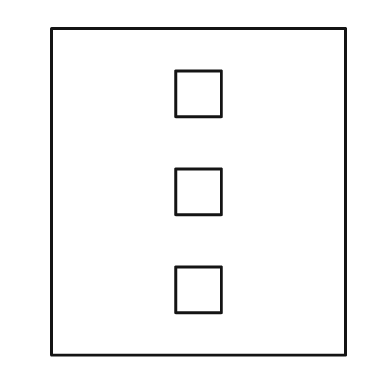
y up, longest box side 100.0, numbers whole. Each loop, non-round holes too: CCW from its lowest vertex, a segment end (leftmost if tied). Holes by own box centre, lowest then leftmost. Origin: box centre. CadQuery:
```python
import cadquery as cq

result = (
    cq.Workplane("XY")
    .moveTo(-45.0, -50.0)
    .lineTo(45.0, -50.0)
    .lineTo(45.0, 50.0)
    .lineTo(-45.0, 50.0)
    .close()
    .moveTo(-7.0, -37.0)
    .lineTo(7.0, -37.0)
    .lineTo(7.0, -23.0)
    .lineTo(-7.0, -23.0)
    .close()
    .moveTo(-7.0, -7.0)
    .lineTo(7.0, -7.0)
    .lineTo(7.0, 7.0)
    .lineTo(-7.0, 7.0)
    .close()
    .moveTo(-7.0, 23.0)
    .lineTo(7.0, 23.0)
    .lineTo(7.0, 37.0)
    .lineTo(-7.0, 37.0)
    .close()
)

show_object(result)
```